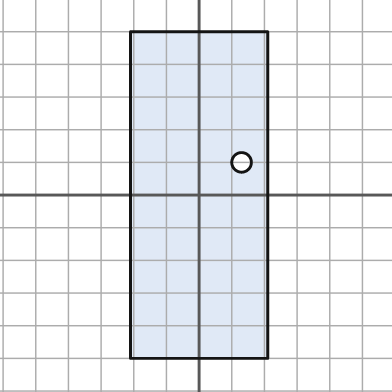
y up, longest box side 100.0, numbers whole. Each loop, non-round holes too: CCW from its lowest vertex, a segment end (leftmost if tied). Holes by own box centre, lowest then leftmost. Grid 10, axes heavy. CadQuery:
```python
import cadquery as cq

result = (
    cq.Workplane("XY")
    .moveTo(-21.0, -50.0)
    .lineTo(21.0, -50.0)
    .lineTo(21.0, 50.0)
    .lineTo(-21.0, 50.0)
    .close()
    .moveTo(13.0, 10.0)
    .circle(3.0)
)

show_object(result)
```